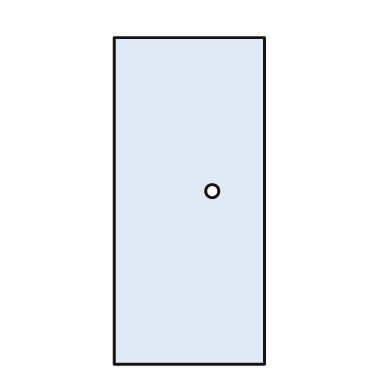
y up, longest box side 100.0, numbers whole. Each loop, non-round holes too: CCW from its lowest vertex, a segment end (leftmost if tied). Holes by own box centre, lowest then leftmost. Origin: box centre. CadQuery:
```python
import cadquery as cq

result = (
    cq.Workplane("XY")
    .moveTo(-23.0, -50.0)
    .lineTo(23.0, -50.0)
    .lineTo(23.0, 50.0)
    .lineTo(-23.0, 50.0)
    .close()
    .moveTo(7.0, 3.0)
    .circle(2.0)
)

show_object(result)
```